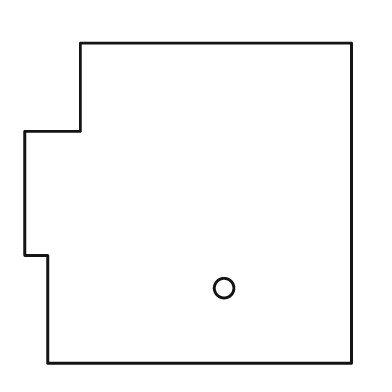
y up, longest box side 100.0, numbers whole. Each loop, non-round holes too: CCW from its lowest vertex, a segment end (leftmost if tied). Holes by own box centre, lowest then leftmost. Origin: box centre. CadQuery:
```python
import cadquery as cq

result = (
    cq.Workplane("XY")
    .moveTo(-43.0, -49.0)
    .lineTo(50.0, -49.0)
    .lineTo(50.0, 49.0)
    .lineTo(-33.0, 49.0)
    .lineTo(-33.0, 22.0)
    .lineTo(-50.0, 22.0)
    .lineTo(-50.0, -16.0)
    .lineTo(-43.0, -16.0)
    .close()
    .moveTo(11.0, -26.0)
    .circle(3.0)
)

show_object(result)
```